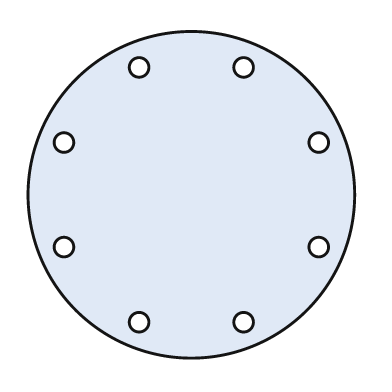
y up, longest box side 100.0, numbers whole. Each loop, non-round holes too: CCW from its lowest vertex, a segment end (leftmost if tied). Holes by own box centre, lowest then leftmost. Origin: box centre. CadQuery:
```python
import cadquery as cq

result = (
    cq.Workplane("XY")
    .moveTo(0.0, 0.0)
    .circle(50.0)
    .moveTo(-16.0, -39.0)
    .circle(3.0)
    .moveTo(16.0, -39.0)
    .circle(3.0)
    .moveTo(-39.0, -16.0)
    .circle(3.0)
    .moveTo(39.0, -16.0)
    .circle(3.0)
    .moveTo(-39.0, 16.0)
    .circle(3.0)
    .moveTo(39.0, 16.0)
    .circle(3.0)
    .moveTo(-16.0, 39.0)
    .circle(3.0)
    .moveTo(16.0, 39.0)
    .circle(3.0)
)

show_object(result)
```